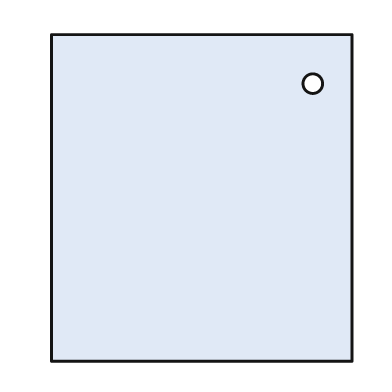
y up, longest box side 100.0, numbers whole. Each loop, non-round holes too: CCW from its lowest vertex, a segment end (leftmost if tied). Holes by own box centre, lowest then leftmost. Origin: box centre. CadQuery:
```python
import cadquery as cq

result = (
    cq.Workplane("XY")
    .moveTo(-46.0, -50.0)
    .lineTo(46.0, -50.0)
    .lineTo(46.0, 50.0)
    .lineTo(-46.0, 50.0)
    .close()
    .moveTo(34.0, 35.0)
    .circle(3.0)
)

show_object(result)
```